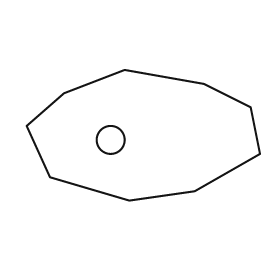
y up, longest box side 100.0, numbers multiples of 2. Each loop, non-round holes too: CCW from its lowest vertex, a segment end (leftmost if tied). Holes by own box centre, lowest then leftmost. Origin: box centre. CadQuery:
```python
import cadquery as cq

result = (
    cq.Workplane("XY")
    .moveTo(-6.0, -28.0)
    .lineTo(22.0, -24.0)
    .lineTo(50.0, -8.0)
    .lineTo(46.0, 12.0)
    .lineTo(26.0, 22.0)
    .lineTo(-8.0, 28.0)
    .lineTo(-34.0, 18.0)
    .lineTo(-50.0, 4.0)
    .lineTo(-40.0, -18.0)
    .close()
    .moveTo(-14.0, -2.0)
    .circle(6.0)
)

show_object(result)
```